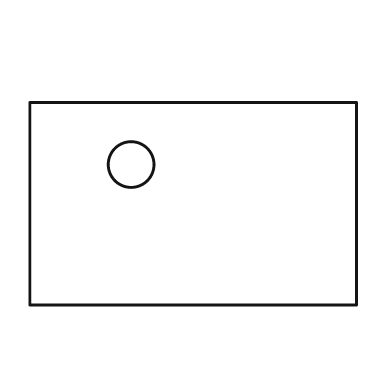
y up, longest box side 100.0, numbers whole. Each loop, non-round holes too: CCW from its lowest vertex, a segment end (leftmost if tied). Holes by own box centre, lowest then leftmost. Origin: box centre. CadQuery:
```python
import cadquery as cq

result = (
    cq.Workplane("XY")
    .moveTo(-50.0, -31.0)
    .lineTo(50.0, -31.0)
    .lineTo(50.0, 31.0)
    .lineTo(-50.0, 31.0)
    .close()
    .moveTo(-19.0, 12.0)
    .circle(7.0)
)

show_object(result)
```